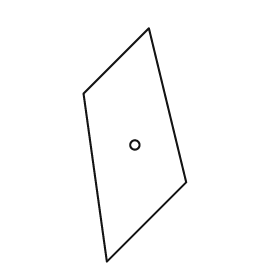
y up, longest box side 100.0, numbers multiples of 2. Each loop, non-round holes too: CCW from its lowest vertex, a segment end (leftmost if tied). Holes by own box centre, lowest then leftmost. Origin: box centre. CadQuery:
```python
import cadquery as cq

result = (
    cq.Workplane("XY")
    .moveTo(-12.0, -50.0)
    .lineTo(22.0, -16.0)
    .lineTo(6.0, 50.0)
    .lineTo(-22.0, 22.0)
    .close()
    .moveTo(0.0, 0.0)
    .circle(2.0)
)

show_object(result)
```